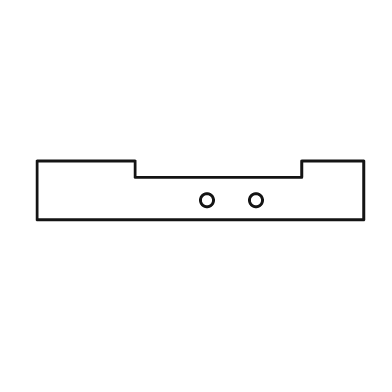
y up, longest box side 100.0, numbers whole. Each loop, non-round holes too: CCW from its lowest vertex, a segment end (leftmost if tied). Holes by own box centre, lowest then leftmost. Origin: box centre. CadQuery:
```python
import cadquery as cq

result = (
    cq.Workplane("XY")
    .moveTo(-50.0, -9.0)
    .lineTo(50.0, -9.0)
    .lineTo(50.0, 9.0)
    .lineTo(31.0, 9.0)
    .lineTo(31.0, 4.0)
    .lineTo(-20.0, 4.0)
    .lineTo(-20.0, 9.0)
    .lineTo(-50.0, 9.0)
    .close()
    .moveTo(2.0, -3.0)
    .circle(2.0)
    .moveTo(17.0, -3.0)
    .circle(2.0)
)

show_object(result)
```